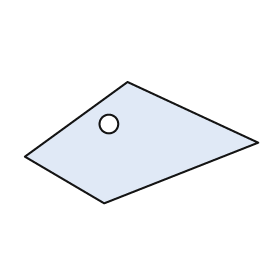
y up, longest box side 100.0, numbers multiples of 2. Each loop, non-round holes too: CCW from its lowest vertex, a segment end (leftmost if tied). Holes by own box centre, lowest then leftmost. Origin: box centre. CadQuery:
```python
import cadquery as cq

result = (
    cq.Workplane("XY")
    .moveTo(-16.0, -26.0)
    .lineTo(50.0, 0.0)
    .lineTo(-6.0, 26.0)
    .lineTo(-50.0, -6.0)
    .close()
    .moveTo(-14.0, 8.0)
    .circle(4.0)
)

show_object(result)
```